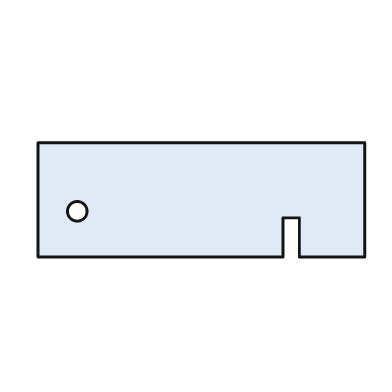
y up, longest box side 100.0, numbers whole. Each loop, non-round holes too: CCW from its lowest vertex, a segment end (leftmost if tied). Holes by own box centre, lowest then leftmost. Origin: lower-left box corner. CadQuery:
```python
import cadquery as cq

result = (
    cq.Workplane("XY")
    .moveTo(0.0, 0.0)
    .lineTo(75.0, 0.0)
    .lineTo(75.0, 12.0)
    .lineTo(80.0, 12.0)
    .lineTo(80.0, 0.0)
    .lineTo(100.0, 0.0)
    .lineTo(100.0, 35.0)
    .lineTo(0.0, 35.0)
    .close()
    .moveTo(12.0, 14.0)
    .circle(3.0)
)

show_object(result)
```